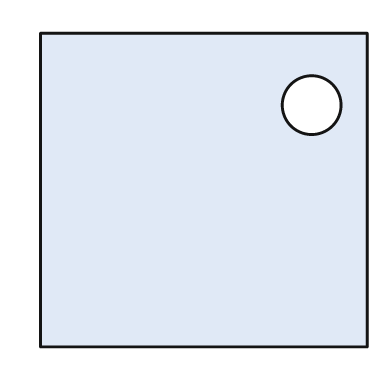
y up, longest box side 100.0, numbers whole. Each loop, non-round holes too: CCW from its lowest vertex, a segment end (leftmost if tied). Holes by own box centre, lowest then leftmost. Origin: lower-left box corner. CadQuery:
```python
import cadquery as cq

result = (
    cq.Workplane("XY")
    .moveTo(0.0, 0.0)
    .lineTo(100.0, 0.0)
    .lineTo(100.0, 96.0)
    .lineTo(0.0, 96.0)
    .close()
    .moveTo(83.0, 74.0)
    .circle(9.0)
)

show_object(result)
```